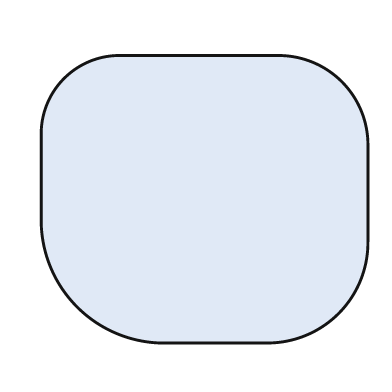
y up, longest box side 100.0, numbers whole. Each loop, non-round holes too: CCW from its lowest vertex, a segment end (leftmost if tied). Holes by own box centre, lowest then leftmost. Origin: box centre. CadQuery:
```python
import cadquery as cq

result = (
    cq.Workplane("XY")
    .moveTo(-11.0, -44.0)
    .lineTo(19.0, -44.0)
    .threePointArc((41.0, -35.0), (50.0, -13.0))
    .lineTo(50.0, 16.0)
    .threePointArc((42.0, 36.0), (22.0, 44.0))
    .lineTo(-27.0, 44.0)
    .threePointArc((-43.0, 37.0), (-50.0, 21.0))
    .lineTo(-50.0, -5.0)
    .threePointArc((-39.0, -33.0), (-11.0, -44.0))
    .close()
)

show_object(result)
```